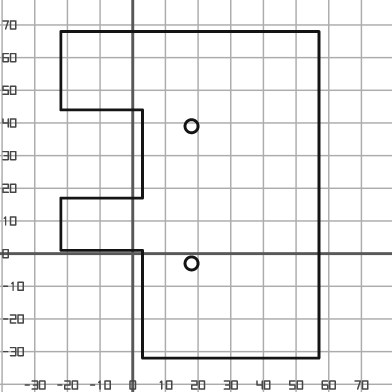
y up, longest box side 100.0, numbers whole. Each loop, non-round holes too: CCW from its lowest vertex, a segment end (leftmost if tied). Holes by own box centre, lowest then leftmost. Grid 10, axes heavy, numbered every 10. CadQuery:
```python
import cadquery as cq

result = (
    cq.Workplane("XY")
    .moveTo(3.0, -32.0)
    .lineTo(57.0, -32.0)
    .lineTo(57.0, 68.0)
    .lineTo(-22.0, 68.0)
    .lineTo(-22.0, 44.0)
    .lineTo(3.0, 44.0)
    .lineTo(3.0, 17.0)
    .lineTo(-22.0, 17.0)
    .lineTo(-22.0, 1.0)
    .lineTo(3.0, 1.0)
    .close()
    .moveTo(18.0, -3.0)
    .circle(2.0)
    .moveTo(18.0, 39.0)
    .circle(2.0)
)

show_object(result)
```